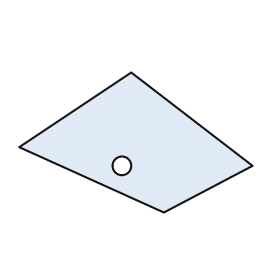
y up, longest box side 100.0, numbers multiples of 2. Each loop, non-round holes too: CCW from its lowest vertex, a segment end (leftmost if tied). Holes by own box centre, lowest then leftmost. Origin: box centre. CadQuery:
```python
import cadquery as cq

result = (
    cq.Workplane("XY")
    .moveTo(12.0, -30.0)
    .lineTo(50.0, -10.0)
    .lineTo(-2.0, 30.0)
    .lineTo(-50.0, -2.0)
    .close()
    .moveTo(-6.0, -10.0)
    .circle(4.0)
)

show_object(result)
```